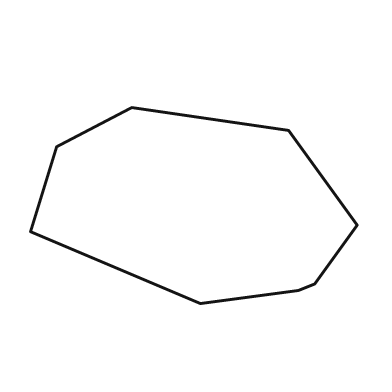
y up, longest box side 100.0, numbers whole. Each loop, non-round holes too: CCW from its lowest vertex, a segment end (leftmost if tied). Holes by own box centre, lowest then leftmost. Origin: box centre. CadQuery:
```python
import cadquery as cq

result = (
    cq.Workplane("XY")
    .moveTo(2.0, -30.0)
    .lineTo(32.0, -26.0)
    .lineTo(37.0, -24.0)
    .lineTo(50.0, -6.0)
    .lineTo(29.0, 23.0)
    .lineTo(-19.0, 30.0)
    .lineTo(-42.0, 18.0)
    .lineTo(-50.0, -8.0)
    .close()
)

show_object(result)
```